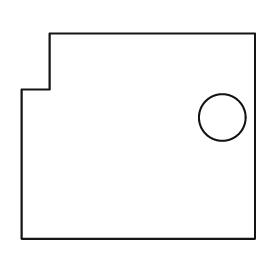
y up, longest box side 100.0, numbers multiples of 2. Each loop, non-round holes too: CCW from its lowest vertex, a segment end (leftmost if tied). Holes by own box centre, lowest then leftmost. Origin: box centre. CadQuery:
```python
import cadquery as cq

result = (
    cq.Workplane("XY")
    .moveTo(-50.0, -44.0)
    .lineTo(50.0, -44.0)
    .lineTo(50.0, 44.0)
    .lineTo(-38.0, 44.0)
    .lineTo(-38.0, 20.0)
    .lineTo(-50.0, 20.0)
    .close()
    .moveTo(36.0, 8.0)
    .circle(10.0)
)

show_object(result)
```